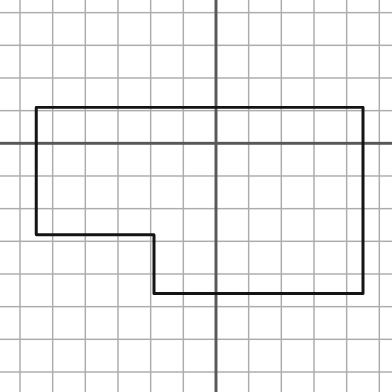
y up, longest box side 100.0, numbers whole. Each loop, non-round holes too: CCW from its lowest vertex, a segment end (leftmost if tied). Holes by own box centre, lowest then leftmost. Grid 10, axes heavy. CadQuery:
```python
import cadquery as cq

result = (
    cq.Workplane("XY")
    .moveTo(-19.0, -46.0)
    .lineTo(45.0, -46.0)
    .lineTo(45.0, 11.0)
    .lineTo(-55.0, 11.0)
    .lineTo(-55.0, -28.0)
    .lineTo(-19.0, -28.0)
    .close()
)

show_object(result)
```